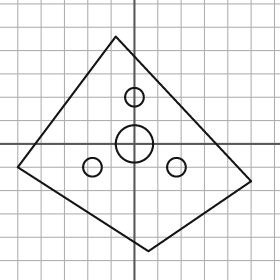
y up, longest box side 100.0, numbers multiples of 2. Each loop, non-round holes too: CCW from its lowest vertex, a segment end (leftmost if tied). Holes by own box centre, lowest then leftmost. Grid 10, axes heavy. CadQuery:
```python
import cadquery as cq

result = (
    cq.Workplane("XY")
    .moveTo(6.0, -46.0)
    .lineTo(50.0, -16.0)
    .lineTo(-8.0, 46.0)
    .lineTo(-50.0, -10.0)
    .close()
    .moveTo(-18.0, -10.0)
    .circle(4.0)
    .moveTo(18.0, -10.0)
    .circle(4.0)
    .moveTo(0.0, 0.0)
    .circle(8.0)
    .moveTo(0.0, 20.0)
    .circle(4.0)
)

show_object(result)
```